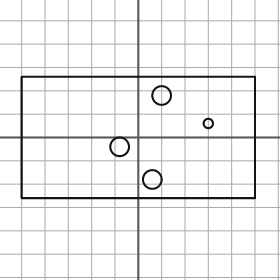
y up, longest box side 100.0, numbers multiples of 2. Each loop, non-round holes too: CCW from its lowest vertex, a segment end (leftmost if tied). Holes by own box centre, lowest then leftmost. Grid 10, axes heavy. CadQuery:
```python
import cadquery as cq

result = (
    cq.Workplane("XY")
    .moveTo(-50.0, -26.0)
    .lineTo(50.0, -26.0)
    .lineTo(50.0, 26.0)
    .lineTo(-50.0, 26.0)
    .close()
    .moveTo(6.0, -18.0)
    .circle(4.0)
    .moveTo(-8.0, -4.0)
    .circle(4.0)
    .moveTo(30.0, 6.0)
    .circle(2.0)
    .moveTo(10.0, 18.0)
    .circle(4.0)
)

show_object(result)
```